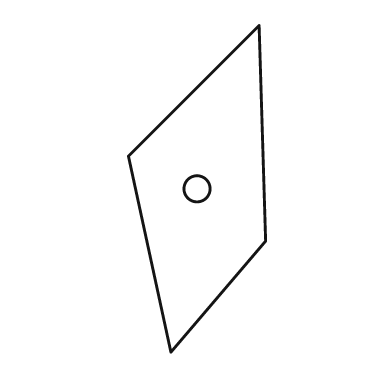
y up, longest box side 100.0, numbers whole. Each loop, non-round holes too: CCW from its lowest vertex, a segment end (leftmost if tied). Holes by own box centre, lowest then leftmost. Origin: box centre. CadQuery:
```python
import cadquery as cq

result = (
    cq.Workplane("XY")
    .moveTo(-8.0, -50.0)
    .lineTo(21.0, -16.0)
    .lineTo(19.0, 50.0)
    .lineTo(-21.0, 10.0)
    .close()
    .moveTo(0.0, 0.0)
    .circle(4.0)
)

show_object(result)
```